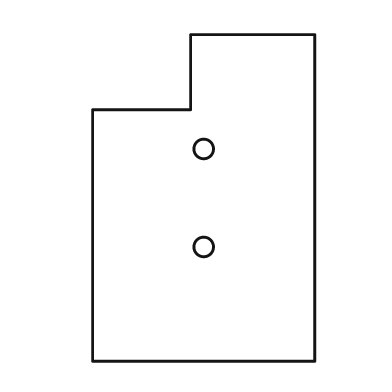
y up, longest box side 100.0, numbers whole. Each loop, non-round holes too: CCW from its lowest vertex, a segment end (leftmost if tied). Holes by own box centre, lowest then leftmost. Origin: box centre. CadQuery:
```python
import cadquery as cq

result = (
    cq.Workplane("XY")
    .moveTo(-34.0, -50.0)
    .lineTo(34.0, -50.0)
    .lineTo(34.0, 50.0)
    .lineTo(-4.0, 50.0)
    .lineTo(-4.0, 27.0)
    .lineTo(-34.0, 27.0)
    .close()
    .moveTo(0.0, -15.0)
    .circle(3.0)
    .moveTo(0.0, 15.0)
    .circle(3.0)
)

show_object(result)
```